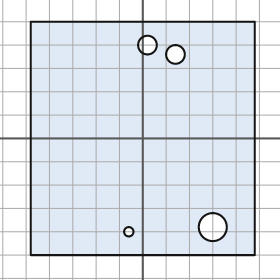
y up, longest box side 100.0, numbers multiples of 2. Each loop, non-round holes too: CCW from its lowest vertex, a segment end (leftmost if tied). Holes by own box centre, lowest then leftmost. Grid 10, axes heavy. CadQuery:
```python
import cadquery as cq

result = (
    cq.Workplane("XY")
    .moveTo(-48.0, -50.0)
    .lineTo(48.0, -50.0)
    .lineTo(48.0, 50.0)
    .lineTo(-48.0, 50.0)
    .close()
    .moveTo(-6.0, -40.0)
    .circle(2.0)
    .moveTo(30.0, -38.0)
    .circle(6.0)
    .moveTo(14.0, 36.0)
    .circle(4.0)
    .moveTo(2.0, 40.0)
    .circle(4.0)
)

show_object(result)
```